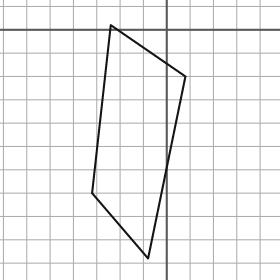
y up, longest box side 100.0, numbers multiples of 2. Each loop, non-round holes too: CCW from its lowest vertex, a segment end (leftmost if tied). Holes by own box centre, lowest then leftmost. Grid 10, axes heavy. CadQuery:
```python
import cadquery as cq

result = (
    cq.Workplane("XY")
    .moveTo(-8.0, -98.0)
    .lineTo(8.0, -20.0)
    .lineTo(-24.0, 2.0)
    .lineTo(-32.0, -70.0)
    .close()
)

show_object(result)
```